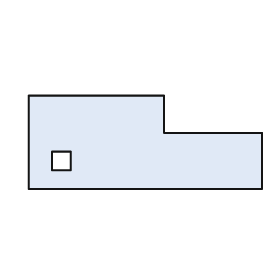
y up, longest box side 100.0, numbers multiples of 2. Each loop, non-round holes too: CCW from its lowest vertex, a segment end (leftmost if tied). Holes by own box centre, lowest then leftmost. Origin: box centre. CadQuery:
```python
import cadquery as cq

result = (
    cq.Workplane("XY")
    .moveTo(-50.0, -20.0)
    .lineTo(50.0, -20.0)
    .lineTo(50.0, 4.0)
    .lineTo(8.0, 4.0)
    .lineTo(8.0, 20.0)
    .lineTo(-50.0, 20.0)
    .close()
    .moveTo(-40.0, -12.0)
    .lineTo(-32.0, -12.0)
    .lineTo(-32.0, -4.0)
    .lineTo(-40.0, -4.0)
    .close()
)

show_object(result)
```